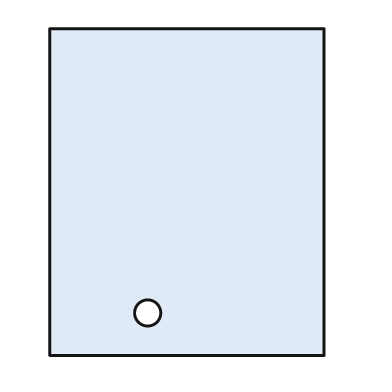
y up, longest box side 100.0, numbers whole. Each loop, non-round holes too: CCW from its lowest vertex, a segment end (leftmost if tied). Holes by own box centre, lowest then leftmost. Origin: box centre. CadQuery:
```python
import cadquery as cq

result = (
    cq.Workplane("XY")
    .moveTo(-42.0, -50.0)
    .lineTo(42.0, -50.0)
    .lineTo(42.0, 50.0)
    .lineTo(-42.0, 50.0)
    .close()
    .moveTo(-12.0, -37.0)
    .circle(4.0)
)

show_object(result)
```